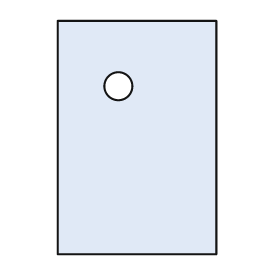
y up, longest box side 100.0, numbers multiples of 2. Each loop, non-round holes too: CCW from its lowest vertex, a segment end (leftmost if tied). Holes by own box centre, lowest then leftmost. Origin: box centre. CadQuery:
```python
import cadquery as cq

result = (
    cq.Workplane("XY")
    .moveTo(-34.0, -50.0)
    .lineTo(34.0, -50.0)
    .lineTo(34.0, 50.0)
    .lineTo(-34.0, 50.0)
    .close()
    .moveTo(-8.0, 22.0)
    .circle(6.0)
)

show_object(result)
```